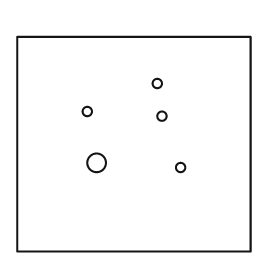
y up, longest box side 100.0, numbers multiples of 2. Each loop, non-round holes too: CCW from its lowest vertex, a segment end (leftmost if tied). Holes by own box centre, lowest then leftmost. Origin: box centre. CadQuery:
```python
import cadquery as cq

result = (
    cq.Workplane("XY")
    .moveTo(-50.0, -46.0)
    .lineTo(50.0, -46.0)
    .lineTo(50.0, 46.0)
    .lineTo(-50.0, 46.0)
    .close()
    .moveTo(20.0, -10.0)
    .circle(2.0)
    .moveTo(-16.0, -8.0)
    .circle(4.0)
    .moveTo(12.0, 12.0)
    .circle(2.0)
    .moveTo(-20.0, 14.0)
    .circle(2.0)
    .moveTo(10.0, 26.0)
    .circle(2.0)
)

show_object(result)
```